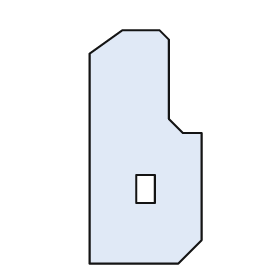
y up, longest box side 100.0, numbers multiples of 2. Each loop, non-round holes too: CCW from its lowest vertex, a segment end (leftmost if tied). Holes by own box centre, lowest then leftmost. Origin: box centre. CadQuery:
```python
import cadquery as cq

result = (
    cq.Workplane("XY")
    .moveTo(-24.0, -50.0)
    .lineTo(14.0, -50.0)
    .lineTo(24.0, -40.0)
    .lineTo(24.0, 6.0)
    .lineTo(16.0, 6.0)
    .lineTo(10.0, 12.0)
    .lineTo(10.0, 46.0)
    .lineTo(6.0, 50.0)
    .lineTo(-10.0, 50.0)
    .lineTo(-24.0, 40.0)
    .close()
    .moveTo(-4.0, -24.0)
    .lineTo(4.0, -24.0)
    .lineTo(4.0, -12.0)
    .lineTo(-4.0, -12.0)
    .close()
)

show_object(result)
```